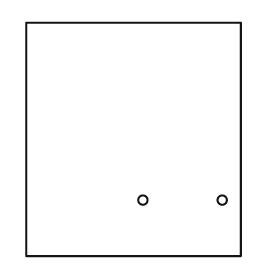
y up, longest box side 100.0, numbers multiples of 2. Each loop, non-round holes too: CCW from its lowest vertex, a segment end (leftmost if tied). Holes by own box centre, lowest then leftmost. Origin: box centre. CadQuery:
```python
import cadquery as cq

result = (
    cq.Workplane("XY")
    .moveTo(-46.0, -50.0)
    .lineTo(46.0, -50.0)
    .lineTo(46.0, 50.0)
    .lineTo(-46.0, 50.0)
    .close()
    .moveTo(4.0, -26.0)
    .circle(2.0)
    .moveTo(38.0, -26.0)
    .circle(2.0)
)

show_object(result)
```